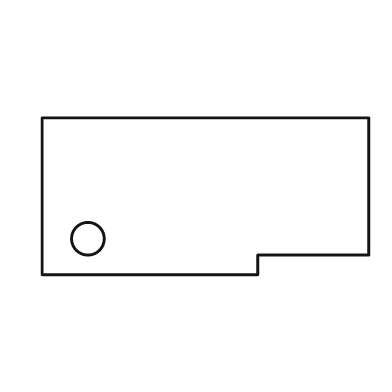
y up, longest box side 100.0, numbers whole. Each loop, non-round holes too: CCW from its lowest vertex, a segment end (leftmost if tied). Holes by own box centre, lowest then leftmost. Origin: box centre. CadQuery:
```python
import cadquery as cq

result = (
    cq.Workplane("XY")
    .moveTo(-50.0, -24.0)
    .lineTo(16.0, -24.0)
    .lineTo(16.0, -18.0)
    .lineTo(50.0, -18.0)
    .lineTo(50.0, 24.0)
    .lineTo(-50.0, 24.0)
    .close()
    .moveTo(-36.0, -13.0)
    .circle(5.0)
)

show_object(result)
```